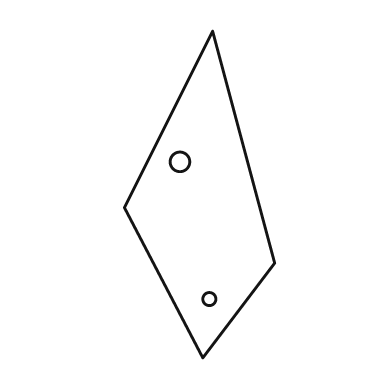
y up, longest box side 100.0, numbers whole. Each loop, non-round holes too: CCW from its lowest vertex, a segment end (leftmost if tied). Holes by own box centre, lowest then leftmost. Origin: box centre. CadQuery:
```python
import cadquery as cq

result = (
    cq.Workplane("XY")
    .moveTo(1.0, -50.0)
    .lineTo(23.0, -21.0)
    .lineTo(4.0, 50.0)
    .lineTo(-23.0, -4.0)
    .close()
    .moveTo(3.0, -32.0)
    .circle(2.0)
    .moveTo(-6.0, 10.0)
    .circle(3.0)
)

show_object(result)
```